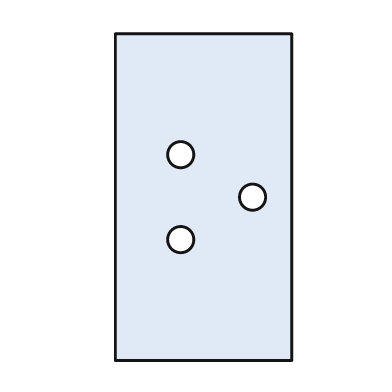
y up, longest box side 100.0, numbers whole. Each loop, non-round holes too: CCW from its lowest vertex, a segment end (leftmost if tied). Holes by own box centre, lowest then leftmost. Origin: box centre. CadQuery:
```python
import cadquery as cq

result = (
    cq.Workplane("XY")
    .moveTo(-27.0, -50.0)
    .lineTo(27.0, -50.0)
    .lineTo(27.0, 50.0)
    .lineTo(-27.0, 50.0)
    .close()
    .moveTo(-7.0, -13.0)
    .circle(4.0)
    .moveTo(15.0, 0.0)
    .circle(4.0)
    .moveTo(-7.0, 13.0)
    .circle(4.0)
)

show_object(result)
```